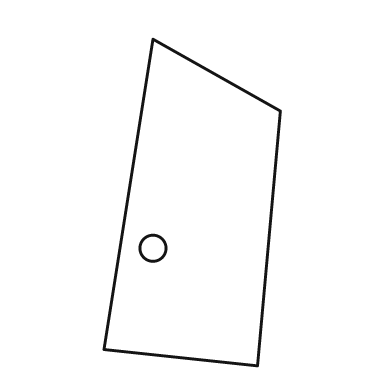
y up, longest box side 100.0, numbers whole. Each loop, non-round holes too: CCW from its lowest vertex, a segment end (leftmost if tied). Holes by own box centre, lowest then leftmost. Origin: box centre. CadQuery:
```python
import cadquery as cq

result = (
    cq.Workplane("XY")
    .moveTo(20.0, -50.0)
    .lineTo(27.0, 28.0)
    .lineTo(-12.0, 50.0)
    .lineTo(-27.0, -45.0)
    .close()
    .moveTo(-12.0, -14.0)
    .circle(4.0)
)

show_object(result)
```